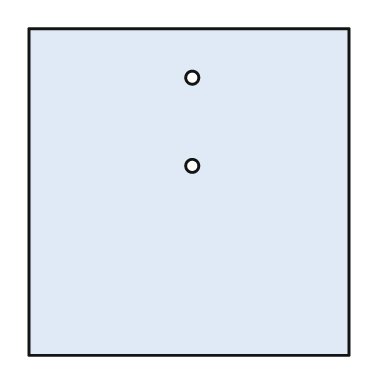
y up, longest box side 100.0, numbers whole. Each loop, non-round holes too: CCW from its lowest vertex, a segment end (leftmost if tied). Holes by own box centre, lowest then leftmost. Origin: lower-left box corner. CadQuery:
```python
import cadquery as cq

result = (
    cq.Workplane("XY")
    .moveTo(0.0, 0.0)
    .lineTo(98.0, 0.0)
    .lineTo(98.0, 100.0)
    .lineTo(0.0, 100.0)
    .close()
    .moveTo(50.0, 58.0)
    .circle(2.0)
    .moveTo(50.0, 85.0)
    .circle(2.0)
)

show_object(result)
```